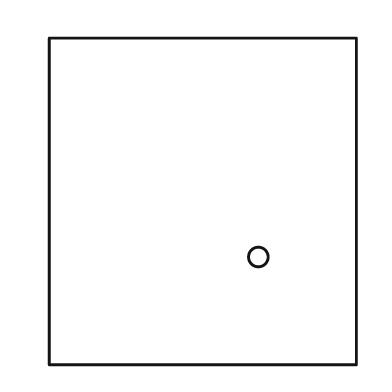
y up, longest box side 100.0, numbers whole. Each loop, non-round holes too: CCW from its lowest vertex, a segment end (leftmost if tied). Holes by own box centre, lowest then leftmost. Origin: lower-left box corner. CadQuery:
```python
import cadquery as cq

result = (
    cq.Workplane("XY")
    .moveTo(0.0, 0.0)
    .lineTo(94.0, 0.0)
    .lineTo(94.0, 100.0)
    .lineTo(0.0, 100.0)
    .close()
    .moveTo(64.0, 33.0)
    .circle(3.0)
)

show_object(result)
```